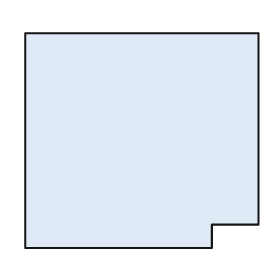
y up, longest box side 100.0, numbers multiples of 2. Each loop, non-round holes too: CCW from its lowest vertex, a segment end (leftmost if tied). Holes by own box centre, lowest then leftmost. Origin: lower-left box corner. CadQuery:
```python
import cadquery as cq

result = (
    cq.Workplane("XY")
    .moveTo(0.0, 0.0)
    .lineTo(80.0, 0.0)
    .lineTo(80.0, 10.0)
    .lineTo(100.0, 10.0)
    .lineTo(100.0, 92.0)
    .lineTo(0.0, 92.0)
    .close()
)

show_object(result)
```